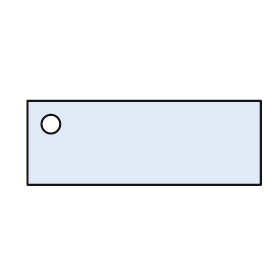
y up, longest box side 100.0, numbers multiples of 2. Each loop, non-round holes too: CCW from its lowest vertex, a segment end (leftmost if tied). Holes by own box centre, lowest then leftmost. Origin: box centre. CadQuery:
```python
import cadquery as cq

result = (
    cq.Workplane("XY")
    .moveTo(-50.0, -18.0)
    .lineTo(50.0, -18.0)
    .lineTo(50.0, 18.0)
    .lineTo(-50.0, 18.0)
    .close()
    .moveTo(-40.0, 8.0)
    .circle(4.0)
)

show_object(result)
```